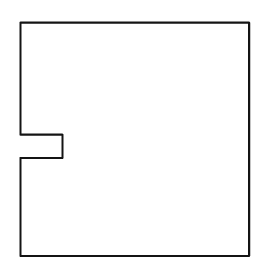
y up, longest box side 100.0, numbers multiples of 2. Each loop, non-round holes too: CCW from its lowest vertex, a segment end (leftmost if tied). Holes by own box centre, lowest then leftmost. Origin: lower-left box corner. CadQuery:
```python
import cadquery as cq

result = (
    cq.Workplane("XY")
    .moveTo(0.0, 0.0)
    .lineTo(98.0, 0.0)
    .lineTo(98.0, 100.0)
    .lineTo(0.0, 100.0)
    .lineTo(0.0, 52.0)
    .lineTo(18.0, 52.0)
    .lineTo(18.0, 42.0)
    .lineTo(0.0, 42.0)
    .close()
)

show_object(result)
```